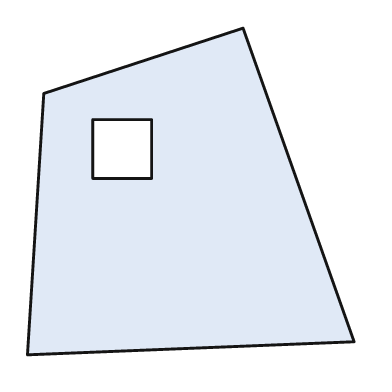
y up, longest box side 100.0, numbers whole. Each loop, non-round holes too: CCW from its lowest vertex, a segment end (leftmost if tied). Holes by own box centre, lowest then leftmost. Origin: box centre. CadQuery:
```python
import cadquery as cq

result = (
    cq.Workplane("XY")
    .moveTo(-50.0, -50.0)
    .lineTo(50.0, -46.0)
    .lineTo(16.0, 50.0)
    .lineTo(-45.0, 30.0)
    .close()
    .moveTo(-30.0, 4.0)
    .lineTo(-12.0, 4.0)
    .lineTo(-12.0, 22.0)
    .lineTo(-30.0, 22.0)
    .close()
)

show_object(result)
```